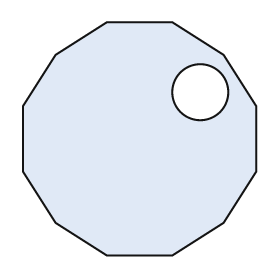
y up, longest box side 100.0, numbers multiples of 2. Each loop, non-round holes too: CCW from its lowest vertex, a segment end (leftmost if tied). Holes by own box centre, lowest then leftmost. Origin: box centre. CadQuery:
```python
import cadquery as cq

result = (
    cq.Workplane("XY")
    .moveTo(-14.0, -50.0)
    .lineTo(14.0, -50.0)
    .lineTo(36.0, -36.0)
    .lineTo(50.0, -14.0)
    .lineTo(50.0, 14.0)
    .lineTo(36.0, 36.0)
    .lineTo(14.0, 50.0)
    .lineTo(-14.0, 50.0)
    .lineTo(-36.0, 36.0)
    .lineTo(-50.0, 14.0)
    .lineTo(-50.0, -14.0)
    .lineTo(-36.0, -36.0)
    .close()
    .moveTo(26.0, 20.0)
    .circle(12.0)
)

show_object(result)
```